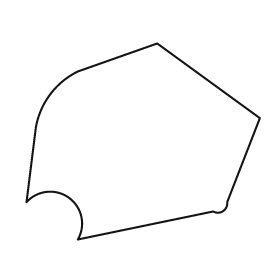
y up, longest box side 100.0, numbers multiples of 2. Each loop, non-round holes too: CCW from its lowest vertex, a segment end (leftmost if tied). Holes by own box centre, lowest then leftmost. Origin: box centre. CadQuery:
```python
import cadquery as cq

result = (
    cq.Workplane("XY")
    .moveTo(-28.0, -42.0)
    .lineTo(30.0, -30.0)
    .threePointArc((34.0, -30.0), (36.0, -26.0))
    .lineTo(50.0, 10.0)
    .lineTo(6.0, 42.0)
    .lineTo(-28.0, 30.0)
    .threePointArc((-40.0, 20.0), (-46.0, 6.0))
    .lineTo(-50.0, -26.0)
    .threePointArc((-32.0, -24.0), (-28.0, -42.0))
    .close()
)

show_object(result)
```